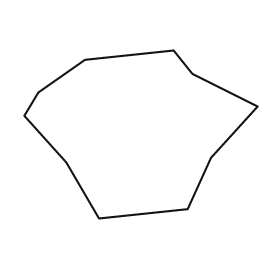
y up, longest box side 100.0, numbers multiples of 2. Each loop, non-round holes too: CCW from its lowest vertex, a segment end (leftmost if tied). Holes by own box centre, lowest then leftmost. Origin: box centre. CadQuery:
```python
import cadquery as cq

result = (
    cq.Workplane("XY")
    .moveTo(-18.0, -36.0)
    .lineTo(20.0, -32.0)
    .lineTo(30.0, -10.0)
    .lineTo(50.0, 12.0)
    .lineTo(22.0, 26.0)
    .lineTo(14.0, 36.0)
    .lineTo(-24.0, 32.0)
    .lineTo(-44.0, 18.0)
    .lineTo(-50.0, 8.0)
    .lineTo(-32.0, -12.0)
    .close()
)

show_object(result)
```